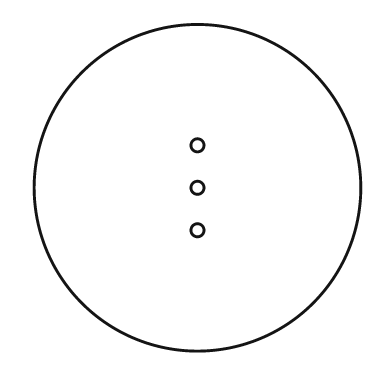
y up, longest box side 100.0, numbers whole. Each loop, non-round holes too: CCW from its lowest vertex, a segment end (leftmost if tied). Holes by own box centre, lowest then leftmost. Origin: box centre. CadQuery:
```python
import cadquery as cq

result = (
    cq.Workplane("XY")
    .moveTo(0.0, 0.0)
    .circle(50.0)
    .moveTo(0.0, -13.0)
    .circle(2.0)
    .moveTo(0.0, 0.0)
    .circle(2.0)
    .moveTo(0.0, 13.0)
    .circle(2.0)
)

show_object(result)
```